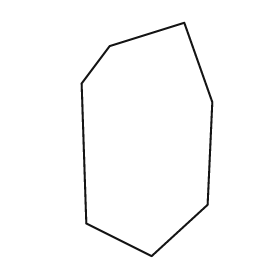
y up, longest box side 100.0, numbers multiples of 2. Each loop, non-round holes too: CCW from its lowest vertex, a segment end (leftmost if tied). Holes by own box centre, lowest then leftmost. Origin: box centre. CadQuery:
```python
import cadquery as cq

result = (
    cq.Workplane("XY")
    .moveTo(2.0, -50.0)
    .lineTo(26.0, -28.0)
    .lineTo(28.0, 16.0)
    .lineTo(16.0, 50.0)
    .lineTo(-16.0, 40.0)
    .lineTo(-28.0, 24.0)
    .lineTo(-26.0, -36.0)
    .close()
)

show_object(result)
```